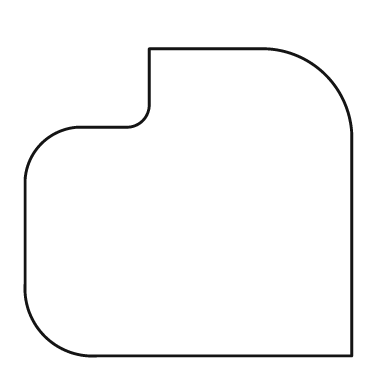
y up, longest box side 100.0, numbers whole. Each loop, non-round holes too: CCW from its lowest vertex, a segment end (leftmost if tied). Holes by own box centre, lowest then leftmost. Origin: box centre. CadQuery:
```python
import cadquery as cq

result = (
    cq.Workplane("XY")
    .moveTo(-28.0, -47.0)
    .lineTo(50.0, -47.0)
    .lineTo(50.0, 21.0)
    .threePointArc((42.0, 39.0), (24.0, 47.0))
    .lineTo(-12.0, 47.0)
    .lineTo(-12.0, 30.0)
    .threePointArc((-14.0, 25.0), (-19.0, 23.0))
    .lineTo(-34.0, 23.0)
    .threePointArc((-45.0, 18.0), (-50.0, 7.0))
    .lineTo(-50.0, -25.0)
    .threePointArc((-44.0, -41.0), (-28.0, -47.0))
    .close()
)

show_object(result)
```